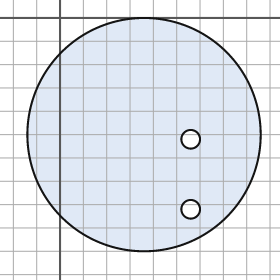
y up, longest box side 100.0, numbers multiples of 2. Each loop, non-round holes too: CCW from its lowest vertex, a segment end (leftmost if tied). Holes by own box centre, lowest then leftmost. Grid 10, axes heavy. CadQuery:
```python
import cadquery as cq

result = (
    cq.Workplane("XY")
    .moveTo(36.0, -50.0)
    .circle(50.0)
    .moveTo(56.0, -82.0)
    .circle(4.0)
    .moveTo(56.0, -52.0)
    .circle(4.0)
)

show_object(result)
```